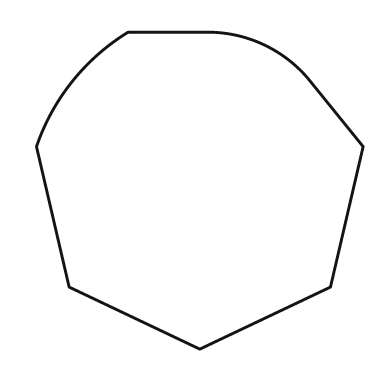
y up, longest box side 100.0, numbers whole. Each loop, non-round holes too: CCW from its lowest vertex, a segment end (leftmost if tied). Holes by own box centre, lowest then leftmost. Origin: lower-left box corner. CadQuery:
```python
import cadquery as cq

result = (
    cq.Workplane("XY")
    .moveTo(50.0, 0.0)
    .lineTo(90.0, 19.0)
    .lineTo(100.0, 62.0)
    .lineTo(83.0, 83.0)
    .threePointArc((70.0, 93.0), (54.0, 97.0))
    .lineTo(28.0, 97.0)
    .threePointArc((11.0, 82.0), (0.0, 62.0))
    .lineTo(10.0, 19.0)
    .close()
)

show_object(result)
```